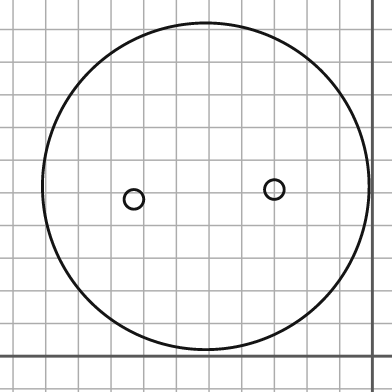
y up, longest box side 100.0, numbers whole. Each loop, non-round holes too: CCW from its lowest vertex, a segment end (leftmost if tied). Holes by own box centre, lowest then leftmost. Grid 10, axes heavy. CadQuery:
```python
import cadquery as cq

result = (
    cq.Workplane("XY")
    .moveTo(-51.0, 52.0)
    .circle(50.0)
    .moveTo(-73.0, 48.0)
    .circle(3.0)
    .moveTo(-30.0, 51.0)
    .circle(3.0)
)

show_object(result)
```